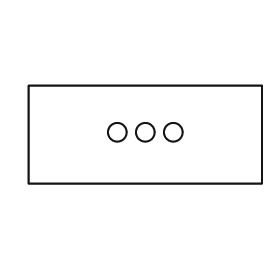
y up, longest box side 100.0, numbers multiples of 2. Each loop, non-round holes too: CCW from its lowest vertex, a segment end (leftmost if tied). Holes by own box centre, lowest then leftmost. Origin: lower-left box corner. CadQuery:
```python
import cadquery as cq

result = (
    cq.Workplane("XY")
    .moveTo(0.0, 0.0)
    .lineTo(100.0, 0.0)
    .lineTo(100.0, 42.0)
    .lineTo(0.0, 42.0)
    .close()
    .moveTo(38.0, 22.0)
    .circle(4.0)
    .moveTo(50.0, 22.0)
    .circle(4.0)
    .moveTo(62.0, 22.0)
    .circle(4.0)
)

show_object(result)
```